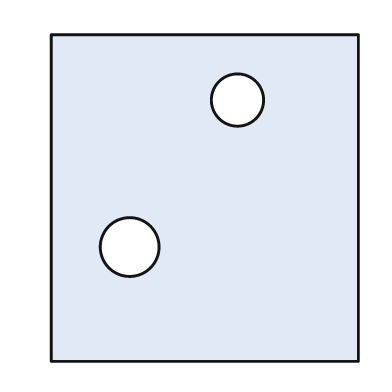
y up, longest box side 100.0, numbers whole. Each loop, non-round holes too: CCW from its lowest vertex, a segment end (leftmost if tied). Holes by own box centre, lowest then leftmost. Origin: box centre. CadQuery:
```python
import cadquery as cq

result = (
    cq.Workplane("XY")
    .moveTo(-47.0, -50.0)
    .lineTo(47.0, -50.0)
    .lineTo(47.0, 50.0)
    .lineTo(-47.0, 50.0)
    .close()
    .moveTo(-23.0, -15.0)
    .circle(9.0)
    .moveTo(10.0, 30.0)
    .circle(8.0)
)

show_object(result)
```